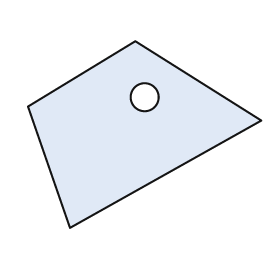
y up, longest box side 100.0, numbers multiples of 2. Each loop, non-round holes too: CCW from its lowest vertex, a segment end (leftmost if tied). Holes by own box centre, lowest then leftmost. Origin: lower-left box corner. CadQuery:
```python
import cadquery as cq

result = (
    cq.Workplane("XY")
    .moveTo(18.0, 0.0)
    .lineTo(100.0, 46.0)
    .lineTo(46.0, 80.0)
    .lineTo(0.0, 52.0)
    .close()
    .moveTo(50.0, 56.0)
    .circle(6.0)
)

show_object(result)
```